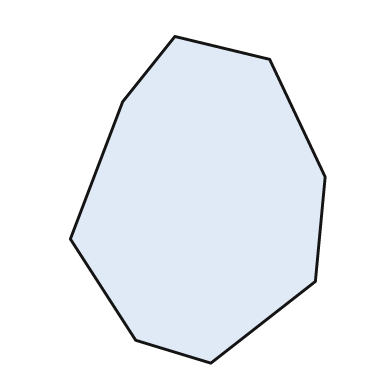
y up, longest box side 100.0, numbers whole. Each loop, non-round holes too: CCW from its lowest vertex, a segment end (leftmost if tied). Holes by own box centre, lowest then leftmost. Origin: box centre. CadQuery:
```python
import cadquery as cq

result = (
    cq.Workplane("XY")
    .moveTo(4.0, -50.0)
    .lineTo(36.0, -25.0)
    .lineTo(39.0, 7.0)
    .lineTo(22.0, 43.0)
    .lineTo(-7.0, 50.0)
    .lineTo(-23.0, 30.0)
    .lineTo(-39.0, -12.0)
    .lineTo(-19.0, -43.0)
    .close()
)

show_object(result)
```